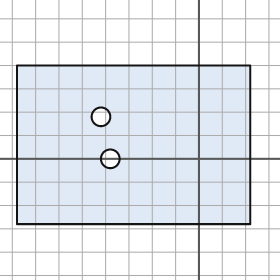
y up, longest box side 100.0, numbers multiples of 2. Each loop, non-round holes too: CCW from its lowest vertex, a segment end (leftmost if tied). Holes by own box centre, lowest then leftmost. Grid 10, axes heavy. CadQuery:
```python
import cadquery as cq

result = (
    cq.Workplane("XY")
    .moveTo(-78.0, -28.0)
    .lineTo(22.0, -28.0)
    .lineTo(22.0, 40.0)
    .lineTo(-78.0, 40.0)
    .close()
    .moveTo(-38.0, 0.0)
    .circle(4.0)
    .moveTo(-42.0, 18.0)
    .circle(4.0)
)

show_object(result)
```